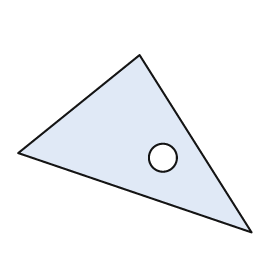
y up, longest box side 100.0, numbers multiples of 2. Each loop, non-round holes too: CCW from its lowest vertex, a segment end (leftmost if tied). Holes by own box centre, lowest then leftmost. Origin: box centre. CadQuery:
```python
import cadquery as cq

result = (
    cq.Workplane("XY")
    .moveTo(50.0, -38.0)
    .lineTo(2.0, 38.0)
    .lineTo(-50.0, -4.0)
    .close()
    .moveTo(12.0, -6.0)
    .circle(6.0)
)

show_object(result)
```